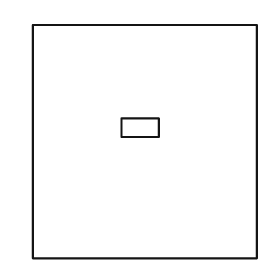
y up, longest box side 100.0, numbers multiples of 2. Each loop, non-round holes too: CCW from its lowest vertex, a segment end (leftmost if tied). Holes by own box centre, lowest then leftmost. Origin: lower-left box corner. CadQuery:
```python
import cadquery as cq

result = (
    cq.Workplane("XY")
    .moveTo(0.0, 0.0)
    .lineTo(96.0, 0.0)
    .lineTo(96.0, 100.0)
    .lineTo(0.0, 100.0)
    .close()
    .moveTo(38.0, 52.0)
    .lineTo(54.0, 52.0)
    .lineTo(54.0, 60.0)
    .lineTo(38.0, 60.0)
    .close()
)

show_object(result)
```